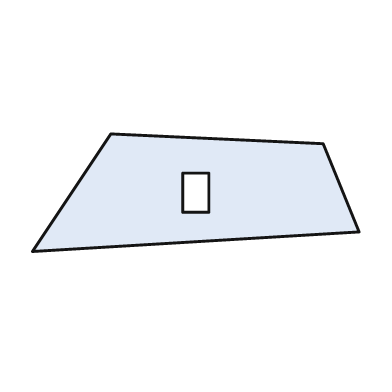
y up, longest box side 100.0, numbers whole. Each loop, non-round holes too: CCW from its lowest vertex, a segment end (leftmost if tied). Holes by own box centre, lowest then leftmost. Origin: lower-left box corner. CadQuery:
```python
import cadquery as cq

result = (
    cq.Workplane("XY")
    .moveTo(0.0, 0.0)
    .lineTo(100.0, 6.0)
    .lineTo(89.0, 33.0)
    .lineTo(24.0, 36.0)
    .close()
    .moveTo(46.0, 12.0)
    .lineTo(54.0, 12.0)
    .lineTo(54.0, 24.0)
    .lineTo(46.0, 24.0)
    .close()
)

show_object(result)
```